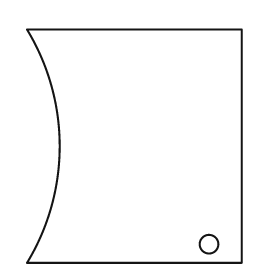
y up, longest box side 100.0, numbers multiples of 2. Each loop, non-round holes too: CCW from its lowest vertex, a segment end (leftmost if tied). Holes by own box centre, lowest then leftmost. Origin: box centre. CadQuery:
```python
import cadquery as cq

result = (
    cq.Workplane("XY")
    .moveTo(-46.0, -50.0)
    .lineTo(46.0, -50.0)
    .lineTo(46.0, 50.0)
    .lineTo(-46.0, 50.0)
    .threePointArc((-32.0, 0.0), (-46.0, -50.0))
    .close()
    .moveTo(32.0, -42.0)
    .circle(4.0)
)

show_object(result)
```